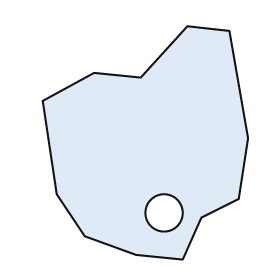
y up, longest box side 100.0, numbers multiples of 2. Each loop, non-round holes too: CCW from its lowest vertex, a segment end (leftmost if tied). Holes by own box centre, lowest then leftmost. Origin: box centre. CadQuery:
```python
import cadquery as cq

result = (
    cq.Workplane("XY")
    .moveTo(16.0, -50.0)
    .lineTo(24.0, -32.0)
    .lineTo(40.0, -24.0)
    .lineTo(44.0, 2.0)
    .lineTo(36.0, 48.0)
    .lineTo(18.0, 50.0)
    .lineTo(-2.0, 28.0)
    .lineTo(-22.0, 30.0)
    .lineTo(-44.0, 18.0)
    .lineTo(-38.0, -22.0)
    .lineTo(-26.0, -40.0)
    .lineTo(-4.0, -48.0)
    .close()
    .moveTo(8.0, -30.0)
    .circle(8.0)
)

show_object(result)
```